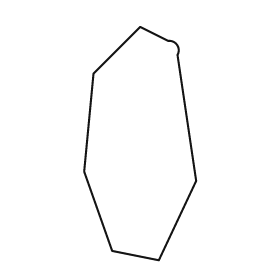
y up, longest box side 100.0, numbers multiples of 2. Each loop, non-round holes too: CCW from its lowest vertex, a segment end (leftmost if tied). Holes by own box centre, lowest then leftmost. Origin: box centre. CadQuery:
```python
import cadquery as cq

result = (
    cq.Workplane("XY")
    .moveTo(8.0, -50.0)
    .lineTo(24.0, -16.0)
    .lineTo(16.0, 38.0)
    .threePointArc((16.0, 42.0), (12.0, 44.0))
    .lineTo(0.0, 50.0)
    .lineTo(-20.0, 30.0)
    .lineTo(-24.0, -12.0)
    .lineTo(-12.0, -46.0)
    .close()
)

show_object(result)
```